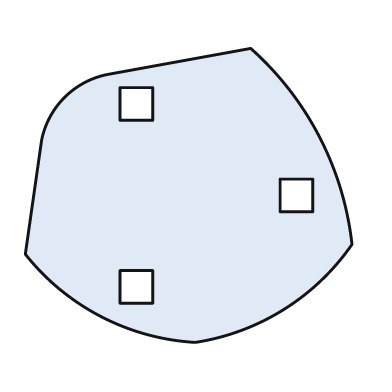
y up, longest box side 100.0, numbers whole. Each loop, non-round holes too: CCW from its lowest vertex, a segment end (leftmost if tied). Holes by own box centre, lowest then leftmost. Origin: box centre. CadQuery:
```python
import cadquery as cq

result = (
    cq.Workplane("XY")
    .moveTo(2.0, -45.0)
    .threePointArc((29.0, -35.0), (50.0, -15.0))
    .threePointArc((40.0, 18.0), (19.0, 45.0))
    .lineTo(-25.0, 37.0)
    .threePointArc((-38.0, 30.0), (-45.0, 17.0))
    .lineTo(-50.0, -18.0)
    .threePointArc((-27.0, -37.0), (2.0, -45.0))
    .close()
    .moveTo(-21.0, -33.0)
    .lineTo(-11.0, -33.0)
    .lineTo(-11.0, -23.0)
    .lineTo(-21.0, -23.0)
    .close()
    .moveTo(28.0, -5.0)
    .lineTo(38.0, -5.0)
    .lineTo(38.0, 5.0)
    .lineTo(28.0, 5.0)
    .close()
    .moveTo(-21.0, 23.0)
    .lineTo(-11.0, 23.0)
    .lineTo(-11.0, 33.0)
    .lineTo(-21.0, 33.0)
    .close()
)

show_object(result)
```